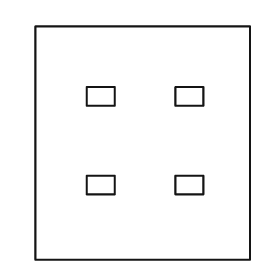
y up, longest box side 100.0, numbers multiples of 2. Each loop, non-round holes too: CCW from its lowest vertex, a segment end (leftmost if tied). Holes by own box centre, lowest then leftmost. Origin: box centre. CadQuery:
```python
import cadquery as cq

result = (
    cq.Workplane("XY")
    .moveTo(-46.0, -50.0)
    .lineTo(46.0, -50.0)
    .lineTo(46.0, 50.0)
    .lineTo(-46.0, 50.0)
    .close()
    .moveTo(-24.0, -22.0)
    .lineTo(-12.0, -22.0)
    .lineTo(-12.0, -14.0)
    .lineTo(-24.0, -14.0)
    .close()
    .moveTo(14.0, -22.0)
    .lineTo(26.0, -22.0)
    .lineTo(26.0, -14.0)
    .lineTo(14.0, -14.0)
    .close()
    .moveTo(-24.0, 16.0)
    .lineTo(-12.0, 16.0)
    .lineTo(-12.0, 24.0)
    .lineTo(-24.0, 24.0)
    .close()
    .moveTo(14.0, 16.0)
    .lineTo(26.0, 16.0)
    .lineTo(26.0, 24.0)
    .lineTo(14.0, 24.0)
    .close()
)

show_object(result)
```